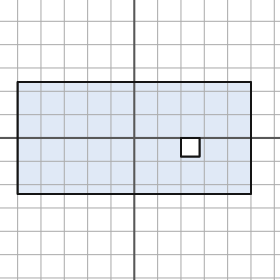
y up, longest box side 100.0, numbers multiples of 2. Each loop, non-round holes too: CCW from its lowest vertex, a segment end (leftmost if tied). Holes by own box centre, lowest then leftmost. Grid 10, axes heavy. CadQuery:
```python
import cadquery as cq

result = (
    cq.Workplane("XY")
    .moveTo(-50.0, -24.0)
    .lineTo(50.0, -24.0)
    .lineTo(50.0, 24.0)
    .lineTo(-50.0, 24.0)
    .close()
    .moveTo(20.0, -8.0)
    .lineTo(28.0, -8.0)
    .lineTo(28.0, 0.0)
    .lineTo(20.0, 0.0)
    .close()
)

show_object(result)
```